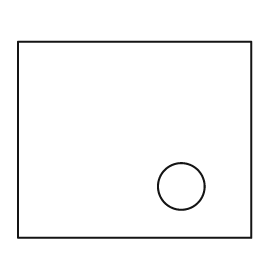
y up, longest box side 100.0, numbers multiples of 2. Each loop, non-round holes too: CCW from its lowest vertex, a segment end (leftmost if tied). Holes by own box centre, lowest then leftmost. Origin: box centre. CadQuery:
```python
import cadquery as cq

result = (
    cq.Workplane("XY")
    .moveTo(-50.0, -42.0)
    .lineTo(50.0, -42.0)
    .lineTo(50.0, 42.0)
    .lineTo(-50.0, 42.0)
    .close()
    .moveTo(20.0, -20.0)
    .circle(10.0)
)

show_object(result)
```